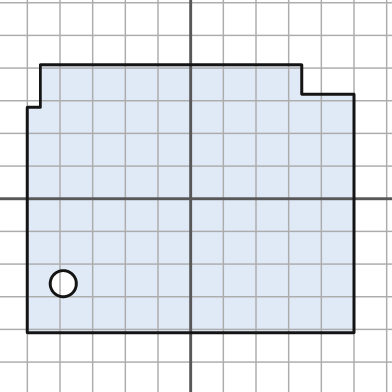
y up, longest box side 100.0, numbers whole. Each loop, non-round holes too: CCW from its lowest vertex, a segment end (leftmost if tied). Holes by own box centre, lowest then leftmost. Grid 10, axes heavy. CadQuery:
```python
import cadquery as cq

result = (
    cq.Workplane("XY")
    .moveTo(-50.0, -41.0)
    .lineTo(50.0, -41.0)
    .lineTo(50.0, 32.0)
    .lineTo(34.0, 32.0)
    .lineTo(34.0, 41.0)
    .lineTo(-46.0, 41.0)
    .lineTo(-46.0, 28.0)
    .lineTo(-50.0, 28.0)
    .close()
    .moveTo(-39.0, -26.0)
    .circle(4.0)
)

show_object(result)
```